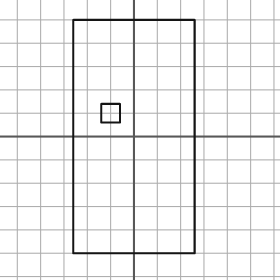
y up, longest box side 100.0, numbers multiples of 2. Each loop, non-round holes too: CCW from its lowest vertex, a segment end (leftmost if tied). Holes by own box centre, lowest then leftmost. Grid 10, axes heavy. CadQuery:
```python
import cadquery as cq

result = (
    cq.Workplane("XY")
    .moveTo(-26.0, -50.0)
    .lineTo(26.0, -50.0)
    .lineTo(26.0, 50.0)
    .lineTo(-26.0, 50.0)
    .close()
    .moveTo(-14.0, 6.0)
    .lineTo(-6.0, 6.0)
    .lineTo(-6.0, 14.0)
    .lineTo(-14.0, 14.0)
    .close()
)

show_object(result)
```